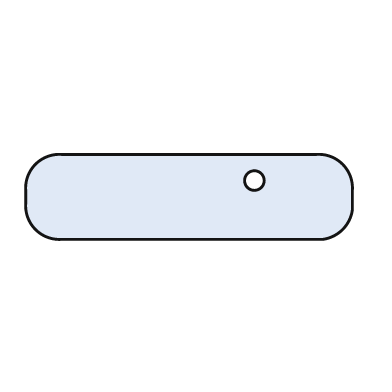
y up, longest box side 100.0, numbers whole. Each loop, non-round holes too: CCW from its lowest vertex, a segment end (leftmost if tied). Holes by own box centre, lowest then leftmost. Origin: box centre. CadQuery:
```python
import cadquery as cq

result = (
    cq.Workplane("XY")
    .moveTo(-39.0, -13.0)
    .lineTo(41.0, -13.0)
    .threePointArc((47.0, -10.0), (50.0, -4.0))
    .lineTo(50.0, 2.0)
    .threePointArc((47.0, 10.0), (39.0, 13.0))
    .lineTo(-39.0, 13.0)
    .threePointArc((-47.0, 10.0), (-50.0, 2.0))
    .lineTo(-50.0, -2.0)
    .threePointArc((-47.0, -10.0), (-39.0, -13.0))
    .close()
    .moveTo(20.0, 5.0)
    .circle(3.0)
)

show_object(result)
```